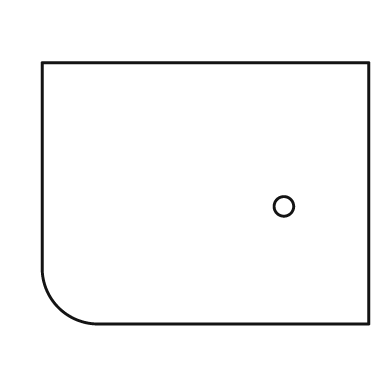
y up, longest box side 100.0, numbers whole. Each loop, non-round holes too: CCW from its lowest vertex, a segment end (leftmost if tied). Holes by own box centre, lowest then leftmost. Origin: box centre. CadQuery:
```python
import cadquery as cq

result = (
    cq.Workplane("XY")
    .moveTo(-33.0, -40.0)
    .lineTo(50.0, -40.0)
    .lineTo(50.0, 40.0)
    .lineTo(-50.0, 40.0)
    .lineTo(-50.0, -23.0)
    .threePointArc((-45.0, -35.0), (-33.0, -40.0))
    .close()
    .moveTo(24.0, -4.0)
    .circle(3.0)
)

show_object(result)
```